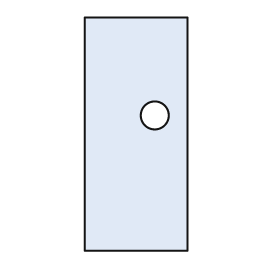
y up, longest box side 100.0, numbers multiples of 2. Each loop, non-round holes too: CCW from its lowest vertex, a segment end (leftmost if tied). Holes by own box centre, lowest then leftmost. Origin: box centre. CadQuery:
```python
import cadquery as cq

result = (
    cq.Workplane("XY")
    .moveTo(-22.0, -50.0)
    .lineTo(22.0, -50.0)
    .lineTo(22.0, 50.0)
    .lineTo(-22.0, 50.0)
    .close()
    .moveTo(8.0, 8.0)
    .circle(6.0)
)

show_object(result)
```